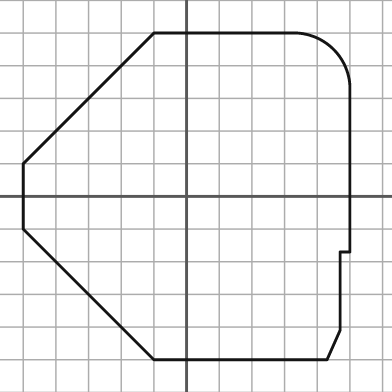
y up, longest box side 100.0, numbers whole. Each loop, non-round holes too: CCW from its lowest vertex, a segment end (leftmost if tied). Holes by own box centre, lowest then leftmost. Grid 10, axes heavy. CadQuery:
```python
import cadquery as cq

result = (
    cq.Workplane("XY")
    .moveTo(-10.0, -50.0)
    .lineTo(43.0, -50.0)
    .lineTo(47.0, -41.0)
    .lineTo(47.0, -17.0)
    .lineTo(50.0, -17.0)
    .lineTo(50.0, 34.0)
    .threePointArc((45.0, 45.0), (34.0, 50.0))
    .lineTo(-10.0, 50.0)
    .lineTo(-50.0, 10.0)
    .lineTo(-50.0, -10.0)
    .close()
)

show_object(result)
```